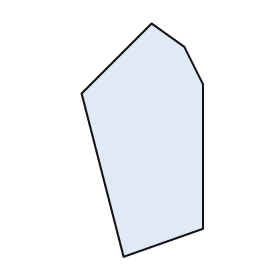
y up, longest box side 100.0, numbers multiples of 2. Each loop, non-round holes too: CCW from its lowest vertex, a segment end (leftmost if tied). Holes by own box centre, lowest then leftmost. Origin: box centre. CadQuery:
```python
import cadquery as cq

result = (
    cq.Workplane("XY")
    .moveTo(-8.0, -50.0)
    .lineTo(26.0, -38.0)
    .lineTo(26.0, 24.0)
    .lineTo(18.0, 40.0)
    .lineTo(4.0, 50.0)
    .lineTo(-26.0, 20.0)
    .close()
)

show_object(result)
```